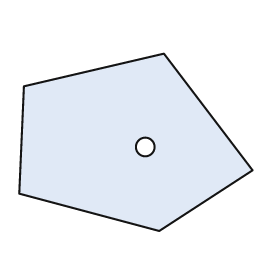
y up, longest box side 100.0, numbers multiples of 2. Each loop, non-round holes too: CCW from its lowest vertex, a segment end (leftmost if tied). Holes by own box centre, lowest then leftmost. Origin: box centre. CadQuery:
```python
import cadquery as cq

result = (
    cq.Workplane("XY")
    .moveTo(10.0, -38.0)
    .lineTo(50.0, -12.0)
    .lineTo(12.0, 38.0)
    .lineTo(-48.0, 24.0)
    .lineTo(-50.0, -22.0)
    .close()
    .moveTo(4.0, -2.0)
    .circle(4.0)
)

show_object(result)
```